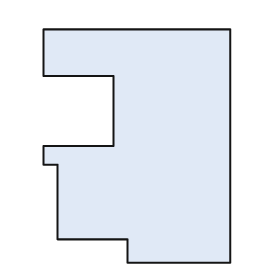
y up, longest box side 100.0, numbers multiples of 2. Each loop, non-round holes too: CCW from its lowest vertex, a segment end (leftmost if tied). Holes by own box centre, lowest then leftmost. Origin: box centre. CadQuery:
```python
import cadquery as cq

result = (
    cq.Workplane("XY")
    .moveTo(-4.0, -50.0)
    .lineTo(40.0, -50.0)
    .lineTo(40.0, 50.0)
    .lineTo(-40.0, 50.0)
    .lineTo(-40.0, 30.0)
    .lineTo(-10.0, 30.0)
    .lineTo(-10.0, 0.0)
    .lineTo(-40.0, 0.0)
    .lineTo(-40.0, -8.0)
    .lineTo(-34.0, -8.0)
    .lineTo(-34.0, -40.0)
    .lineTo(-4.0, -40.0)
    .close()
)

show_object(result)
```